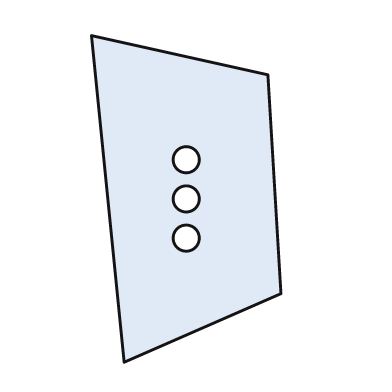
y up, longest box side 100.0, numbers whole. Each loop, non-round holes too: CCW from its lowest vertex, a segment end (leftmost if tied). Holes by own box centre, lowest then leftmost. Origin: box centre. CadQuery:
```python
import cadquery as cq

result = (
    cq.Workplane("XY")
    .moveTo(-19.0, -50.0)
    .lineTo(29.0, -29.0)
    .lineTo(25.0, 38.0)
    .lineTo(-29.0, 50.0)
    .close()
    .moveTo(0.0, -12.0)
    .circle(4.0)
    .moveTo(0.0, 0.0)
    .circle(4.0)
    .moveTo(0.0, 12.0)
    .circle(4.0)
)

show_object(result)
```